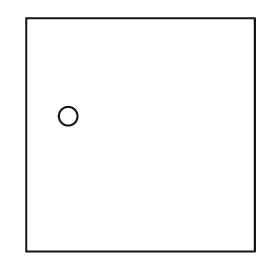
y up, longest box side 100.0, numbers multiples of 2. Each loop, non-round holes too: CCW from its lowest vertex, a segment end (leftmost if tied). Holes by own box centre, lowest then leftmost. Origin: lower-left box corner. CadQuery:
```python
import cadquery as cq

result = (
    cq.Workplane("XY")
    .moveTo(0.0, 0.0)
    .lineTo(98.0, 0.0)
    .lineTo(98.0, 100.0)
    .lineTo(0.0, 100.0)
    .close()
    .moveTo(18.0, 58.0)
    .circle(4.0)
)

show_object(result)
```